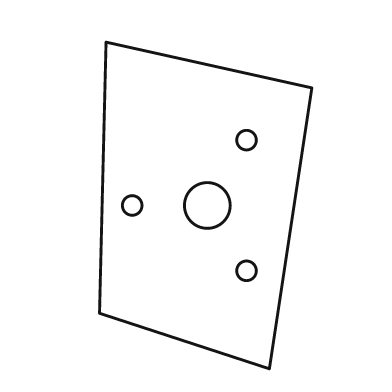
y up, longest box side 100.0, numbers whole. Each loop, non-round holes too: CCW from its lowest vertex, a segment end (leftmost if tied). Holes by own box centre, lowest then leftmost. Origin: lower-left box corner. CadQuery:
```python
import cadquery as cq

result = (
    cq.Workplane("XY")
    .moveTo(52.0, 0.0)
    .lineTo(65.0, 86.0)
    .lineTo(2.0, 100.0)
    .lineTo(0.0, 17.0)
    .close()
    .moveTo(45.0, 30.0)
    .circle(3.0)
    .moveTo(10.0, 50.0)
    .circle(3.0)
    .moveTo(33.0, 50.0)
    .circle(7.0)
    .moveTo(45.0, 70.0)
    .circle(3.0)
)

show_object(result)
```